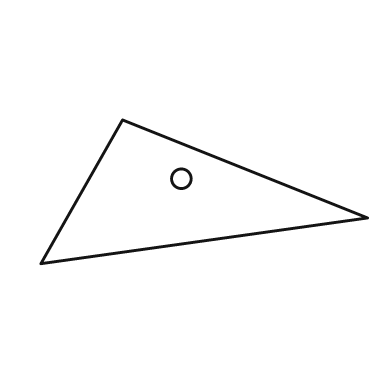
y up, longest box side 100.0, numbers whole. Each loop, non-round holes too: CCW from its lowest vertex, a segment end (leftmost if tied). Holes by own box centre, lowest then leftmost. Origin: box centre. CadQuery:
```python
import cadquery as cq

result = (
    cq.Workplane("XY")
    .moveTo(-50.0, -22.0)
    .lineTo(50.0, -8.0)
    .lineTo(-25.0, 22.0)
    .close()
    .moveTo(-7.0, 4.0)
    .circle(3.0)
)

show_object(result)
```